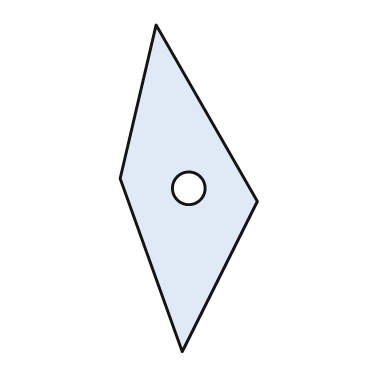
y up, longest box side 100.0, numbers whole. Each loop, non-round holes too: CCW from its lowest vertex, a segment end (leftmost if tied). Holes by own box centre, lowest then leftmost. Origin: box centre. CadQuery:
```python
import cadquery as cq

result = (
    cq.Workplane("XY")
    .moveTo(-2.0, -50.0)
    .lineTo(21.0, -4.0)
    .lineTo(-10.0, 50.0)
    .lineTo(-21.0, 3.0)
    .close()
    .moveTo(0.0, 0.0)
    .circle(5.0)
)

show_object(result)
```